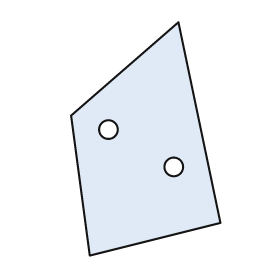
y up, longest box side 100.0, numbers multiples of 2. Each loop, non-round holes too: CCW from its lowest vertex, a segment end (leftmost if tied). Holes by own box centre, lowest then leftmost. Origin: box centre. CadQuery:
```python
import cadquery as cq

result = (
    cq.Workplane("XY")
    .moveTo(-24.0, -50.0)
    .lineTo(32.0, -36.0)
    .lineTo(14.0, 50.0)
    .lineTo(-32.0, 10.0)
    .close()
    .moveTo(12.0, -12.0)
    .circle(4.0)
    .moveTo(-16.0, 4.0)
    .circle(4.0)
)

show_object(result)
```